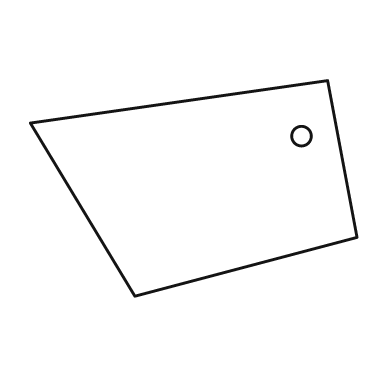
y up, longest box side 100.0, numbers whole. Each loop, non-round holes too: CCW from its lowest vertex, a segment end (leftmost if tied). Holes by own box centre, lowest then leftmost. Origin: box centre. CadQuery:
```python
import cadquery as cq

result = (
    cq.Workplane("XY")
    .moveTo(-18.0, -33.0)
    .lineTo(50.0, -15.0)
    .lineTo(41.0, 33.0)
    .lineTo(-50.0, 20.0)
    .close()
    .moveTo(33.0, 16.0)
    .circle(3.0)
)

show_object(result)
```